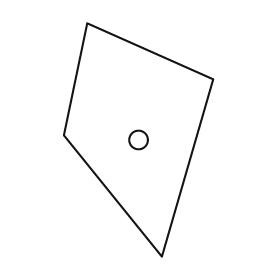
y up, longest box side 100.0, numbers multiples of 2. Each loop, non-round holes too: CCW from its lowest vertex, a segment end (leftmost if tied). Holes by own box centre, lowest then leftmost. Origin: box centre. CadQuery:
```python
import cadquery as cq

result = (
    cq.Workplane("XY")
    .moveTo(10.0, -50.0)
    .lineTo(32.0, 26.0)
    .lineTo(-22.0, 50.0)
    .lineTo(-32.0, 2.0)
    .close()
    .moveTo(0.0, 0.0)
    .circle(4.0)
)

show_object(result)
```